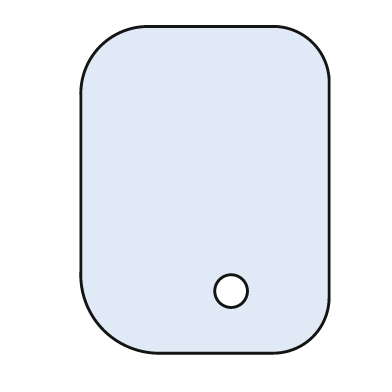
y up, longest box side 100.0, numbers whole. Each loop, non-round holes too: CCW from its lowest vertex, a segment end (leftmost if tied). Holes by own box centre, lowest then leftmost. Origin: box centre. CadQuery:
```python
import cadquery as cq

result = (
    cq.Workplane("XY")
    .moveTo(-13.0, -50.0)
    .lineTo(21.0, -50.0)
    .threePointArc((33.0, -45.0), (38.0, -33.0))
    .lineTo(38.0, 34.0)
    .threePointArc((33.0, 45.0), (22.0, 50.0))
    .lineTo(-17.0, 50.0)
    .threePointArc((-32.0, 44.0), (-38.0, 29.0))
    .lineTo(-38.0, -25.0)
    .threePointArc((-31.0, -43.0), (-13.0, -50.0))
    .close()
    .moveTo(8.0, -31.0)
    .circle(5.0)
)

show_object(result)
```